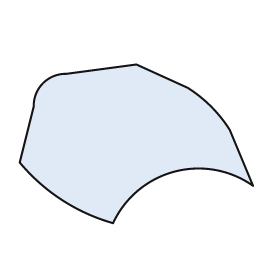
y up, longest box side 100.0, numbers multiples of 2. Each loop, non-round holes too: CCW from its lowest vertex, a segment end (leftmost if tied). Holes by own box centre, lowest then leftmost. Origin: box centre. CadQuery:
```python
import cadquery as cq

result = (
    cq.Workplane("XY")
    .moveTo(-10.0, -34.0)
    .threePointArc((16.0, -12.0), (50.0, -18.0))
    .lineTo(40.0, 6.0)
    .threePointArc((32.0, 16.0), (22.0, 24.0))
    .lineTo(0.0, 34.0)
    .lineTo(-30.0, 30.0)
    .threePointArc((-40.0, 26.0), (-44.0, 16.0))
    .lineTo(-50.0, -8.0)
    .threePointArc((-32.0, -24.0), (-10.0, -34.0))
    .close()
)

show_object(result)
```